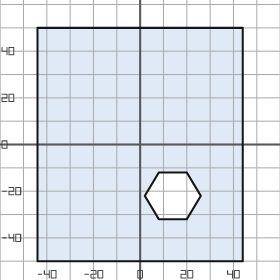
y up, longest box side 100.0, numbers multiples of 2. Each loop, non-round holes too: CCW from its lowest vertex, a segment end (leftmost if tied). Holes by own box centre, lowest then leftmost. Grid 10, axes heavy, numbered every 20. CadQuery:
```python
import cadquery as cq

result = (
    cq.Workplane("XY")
    .moveTo(-44.0, -50.0)
    .lineTo(44.0, -50.0)
    .lineTo(44.0, 50.0)
    .lineTo(-44.0, 50.0)
    .close()
    .moveTo(8.0, -32.0)
    .lineTo(20.0, -32.0)
    .lineTo(26.0, -22.0)
    .lineTo(20.0, -12.0)
    .lineTo(8.0, -12.0)
    .lineTo(2.0, -22.0)
    .close()
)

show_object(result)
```